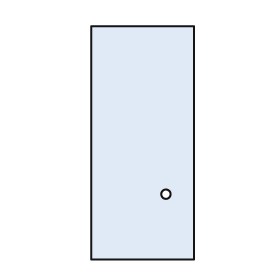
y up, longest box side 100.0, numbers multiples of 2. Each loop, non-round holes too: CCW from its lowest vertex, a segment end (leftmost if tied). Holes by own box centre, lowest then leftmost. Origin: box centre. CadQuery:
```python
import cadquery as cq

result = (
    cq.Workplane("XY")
    .moveTo(-22.0, -50.0)
    .lineTo(22.0, -50.0)
    .lineTo(22.0, 50.0)
    .lineTo(-22.0, 50.0)
    .close()
    .moveTo(10.0, -22.0)
    .circle(2.0)
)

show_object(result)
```